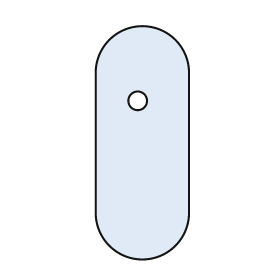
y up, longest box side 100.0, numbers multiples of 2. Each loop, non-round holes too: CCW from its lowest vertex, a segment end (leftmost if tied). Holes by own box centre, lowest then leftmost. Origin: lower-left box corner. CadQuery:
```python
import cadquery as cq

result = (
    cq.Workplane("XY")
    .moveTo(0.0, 20.0)
    .threePointArc((20.0, 0.0), (40.0, 20.0))
    .lineTo(40.0, 80.0)
    .threePointArc((20.0, 100.0), (0.0, 80.0))
    .close()
    .moveTo(18.0, 68.0)
    .circle(4.0)
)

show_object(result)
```